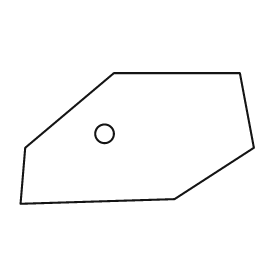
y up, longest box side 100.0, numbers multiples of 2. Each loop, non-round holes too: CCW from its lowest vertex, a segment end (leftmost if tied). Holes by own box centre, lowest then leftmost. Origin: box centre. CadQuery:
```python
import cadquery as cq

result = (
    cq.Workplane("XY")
    .moveTo(-50.0, -28.0)
    .lineTo(16.0, -26.0)
    .lineTo(50.0, -4.0)
    .lineTo(44.0, 28.0)
    .lineTo(-10.0, 28.0)
    .lineTo(-48.0, -4.0)
    .close()
    .moveTo(-14.0, 2.0)
    .circle(4.0)
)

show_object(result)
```